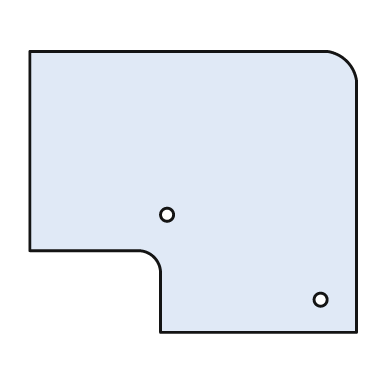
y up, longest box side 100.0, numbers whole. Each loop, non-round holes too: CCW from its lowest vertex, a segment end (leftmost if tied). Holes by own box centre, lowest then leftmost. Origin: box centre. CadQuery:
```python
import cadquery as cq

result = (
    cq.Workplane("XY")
    .moveTo(-10.0, -43.0)
    .lineTo(50.0, -43.0)
    .lineTo(50.0, 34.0)
    .threePointArc((47.0, 40.0), (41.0, 43.0))
    .lineTo(-50.0, 43.0)
    .lineTo(-50.0, -18.0)
    .lineTo(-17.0, -18.0)
    .threePointArc((-12.0, -20.0), (-10.0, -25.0))
    .close()
    .moveTo(39.0, -33.0)
    .circle(2.0)
    .moveTo(-8.0, -7.0)
    .circle(2.0)
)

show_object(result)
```